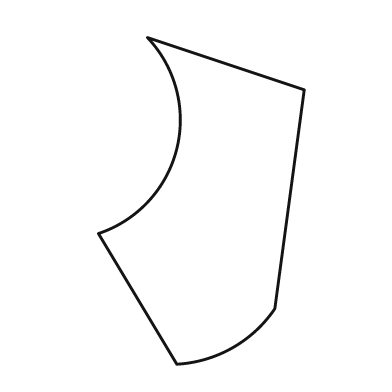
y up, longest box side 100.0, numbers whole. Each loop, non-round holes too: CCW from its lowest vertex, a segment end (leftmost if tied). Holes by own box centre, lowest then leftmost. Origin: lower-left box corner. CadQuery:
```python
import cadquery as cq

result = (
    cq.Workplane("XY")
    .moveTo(24.0, 0.0)
    .threePointArc((41.0, 5.0), (54.0, 17.0))
    .lineTo(63.0, 84.0)
    .lineTo(15.0, 100.0)
    .threePointArc((24.0, 66.0), (0.0, 40.0))
    .close()
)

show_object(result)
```